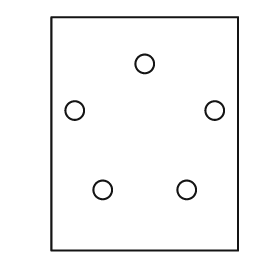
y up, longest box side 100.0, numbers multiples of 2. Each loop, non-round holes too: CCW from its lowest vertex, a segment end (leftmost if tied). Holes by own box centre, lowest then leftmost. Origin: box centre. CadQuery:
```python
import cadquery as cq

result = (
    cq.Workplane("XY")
    .moveTo(-40.0, -50.0)
    .lineTo(40.0, -50.0)
    .lineTo(40.0, 50.0)
    .lineTo(-40.0, 50.0)
    .close()
    .moveTo(-18.0, -24.0)
    .circle(4.0)
    .moveTo(18.0, -24.0)
    .circle(4.0)
    .moveTo(-30.0, 10.0)
    .circle(4.0)
    .moveTo(30.0, 10.0)
    .circle(4.0)
    .moveTo(0.0, 30.0)
    .circle(4.0)
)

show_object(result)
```